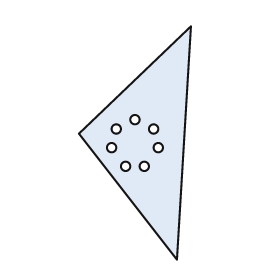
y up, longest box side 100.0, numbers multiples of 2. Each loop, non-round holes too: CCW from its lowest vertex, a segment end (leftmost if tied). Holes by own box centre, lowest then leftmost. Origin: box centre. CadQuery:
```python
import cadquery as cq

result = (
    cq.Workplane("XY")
    .moveTo(18.0, -50.0)
    .lineTo(24.0, 50.0)
    .lineTo(-24.0, 4.0)
    .close()
    .moveTo(-4.0, -10.0)
    .circle(2.0)
    .moveTo(4.0, -10.0)
    .circle(2.0)
    .moveTo(-10.0, -2.0)
    .circle(2.0)
    .moveTo(10.0, -2.0)
    .circle(2.0)
    .moveTo(-8.0, 6.0)
    .circle(2.0)
    .moveTo(8.0, 6.0)
    .circle(2.0)
    .moveTo(0.0, 10.0)
    .circle(2.0)
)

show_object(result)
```